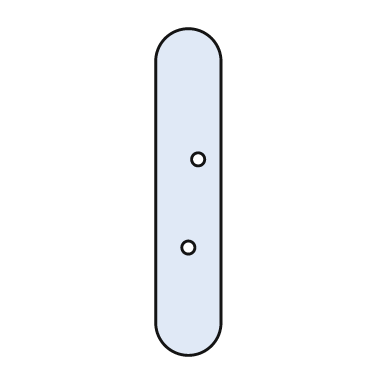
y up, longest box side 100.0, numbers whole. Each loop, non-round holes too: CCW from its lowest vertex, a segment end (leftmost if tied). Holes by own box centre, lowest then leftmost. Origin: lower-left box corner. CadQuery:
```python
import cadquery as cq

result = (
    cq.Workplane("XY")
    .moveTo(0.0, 10.0)
    .threePointArc((10.0, 0.0), (20.0, 10.0))
    .lineTo(20.0, 90.0)
    .threePointArc((10.0, 100.0), (0.0, 90.0))
    .close()
    .moveTo(10.0, 33.0)
    .circle(2.0)
    .moveTo(13.0, 60.0)
    .circle(2.0)
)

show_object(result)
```